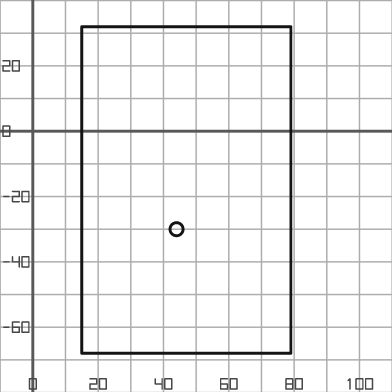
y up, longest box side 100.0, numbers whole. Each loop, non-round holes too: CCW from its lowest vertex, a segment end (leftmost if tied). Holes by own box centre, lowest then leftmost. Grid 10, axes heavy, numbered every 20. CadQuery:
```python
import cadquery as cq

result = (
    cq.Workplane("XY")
    .moveTo(15.0, -68.0)
    .lineTo(79.0, -68.0)
    .lineTo(79.0, 32.0)
    .lineTo(15.0, 32.0)
    .close()
    .moveTo(44.0, -30.0)
    .circle(2.0)
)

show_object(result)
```